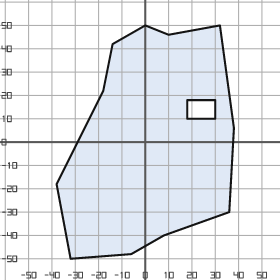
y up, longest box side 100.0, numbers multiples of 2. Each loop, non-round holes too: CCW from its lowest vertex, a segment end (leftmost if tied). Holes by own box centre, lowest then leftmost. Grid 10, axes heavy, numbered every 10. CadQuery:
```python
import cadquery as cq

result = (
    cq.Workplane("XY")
    .moveTo(-32.0, -50.0)
    .lineTo(-6.0, -48.0)
    .lineTo(8.0, -40.0)
    .lineTo(36.0, -30.0)
    .lineTo(38.0, 6.0)
    .lineTo(32.0, 50.0)
    .lineTo(10.0, 46.0)
    .lineTo(0.0, 50.0)
    .lineTo(-14.0, 42.0)
    .lineTo(-18.0, 22.0)
    .lineTo(-38.0, -18.0)
    .close()
    .moveTo(18.0, 10.0)
    .lineTo(30.0, 10.0)
    .lineTo(30.0, 18.0)
    .lineTo(18.0, 18.0)
    .close()
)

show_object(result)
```